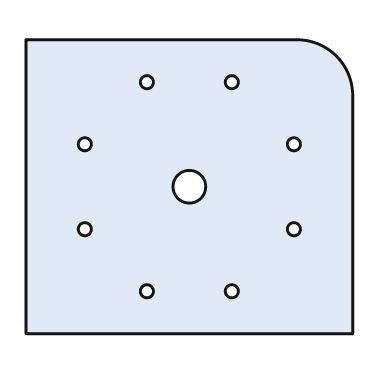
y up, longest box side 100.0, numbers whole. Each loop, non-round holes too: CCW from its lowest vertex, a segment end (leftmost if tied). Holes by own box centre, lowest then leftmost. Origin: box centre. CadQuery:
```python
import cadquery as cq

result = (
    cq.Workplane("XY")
    .moveTo(-50.0, -45.0)
    .lineTo(50.0, -45.0)
    .lineTo(50.0, 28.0)
    .threePointArc((45.0, 40.0), (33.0, 45.0))
    .lineTo(-50.0, 45.0)
    .close()
    .moveTo(-13.0, -32.0)
    .circle(2.0)
    .moveTo(13.0, -32.0)
    .circle(2.0)
    .moveTo(-32.0, -13.0)
    .circle(2.0)
    .moveTo(32.0, -13.0)
    .circle(2.0)
    .moveTo(0.0, 0.0)
    .circle(5.0)
    .moveTo(-32.0, 13.0)
    .circle(2.0)
    .moveTo(32.0, 13.0)
    .circle(2.0)
    .moveTo(-13.0, 32.0)
    .circle(2.0)
    .moveTo(13.0, 32.0)
    .circle(2.0)
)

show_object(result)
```